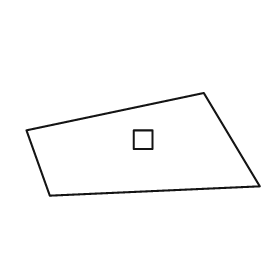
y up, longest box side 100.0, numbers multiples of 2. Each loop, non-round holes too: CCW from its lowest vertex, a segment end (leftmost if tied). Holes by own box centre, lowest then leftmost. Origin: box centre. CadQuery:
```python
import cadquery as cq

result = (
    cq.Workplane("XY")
    .moveTo(-40.0, -22.0)
    .lineTo(50.0, -18.0)
    .lineTo(26.0, 22.0)
    .lineTo(-50.0, 6.0)
    .close()
    .moveTo(-4.0, -2.0)
    .lineTo(4.0, -2.0)
    .lineTo(4.0, 6.0)
    .lineTo(-4.0, 6.0)
    .close()
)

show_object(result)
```